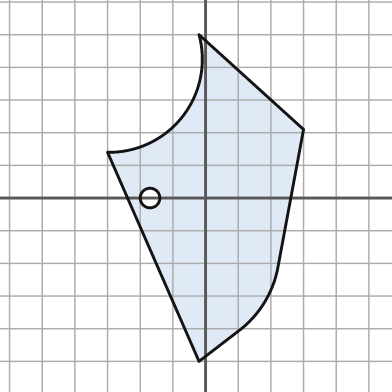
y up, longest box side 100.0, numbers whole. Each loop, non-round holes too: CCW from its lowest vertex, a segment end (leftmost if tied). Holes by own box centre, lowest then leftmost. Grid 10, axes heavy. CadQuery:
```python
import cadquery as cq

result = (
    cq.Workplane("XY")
    .moveTo(-2.0, -50.0)
    .lineTo(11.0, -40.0)
    .threePointArc((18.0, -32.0), (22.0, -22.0))
    .lineTo(30.0, 21.0)
    .lineTo(-2.0, 50.0)
    .threePointArc((-7.0, 25.0), (-30.0, 14.0))
    .close()
    .moveTo(-17.0, 0.0)
    .circle(3.0)
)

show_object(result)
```